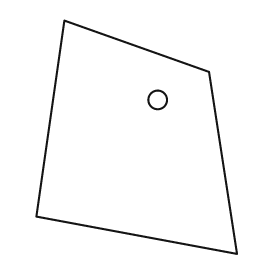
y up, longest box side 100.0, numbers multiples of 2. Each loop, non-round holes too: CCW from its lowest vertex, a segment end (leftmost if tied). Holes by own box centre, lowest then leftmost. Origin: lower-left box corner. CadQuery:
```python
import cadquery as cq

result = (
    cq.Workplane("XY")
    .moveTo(86.0, 0.0)
    .lineTo(74.0, 78.0)
    .lineTo(12.0, 100.0)
    .lineTo(0.0, 16.0)
    .close()
    .moveTo(52.0, 66.0)
    .circle(4.0)
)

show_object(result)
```